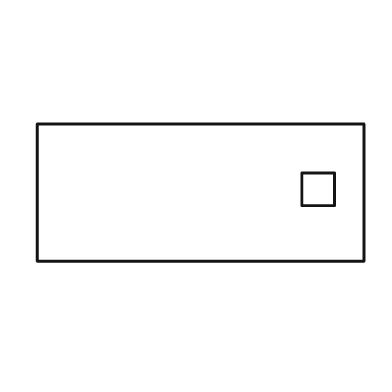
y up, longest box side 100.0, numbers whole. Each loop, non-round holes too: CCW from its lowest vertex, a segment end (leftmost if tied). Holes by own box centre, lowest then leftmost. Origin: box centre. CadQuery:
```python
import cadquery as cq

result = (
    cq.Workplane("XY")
    .moveTo(-50.0, -21.0)
    .lineTo(50.0, -21.0)
    .lineTo(50.0, 21.0)
    .lineTo(-50.0, 21.0)
    .close()
    .moveTo(31.0, -4.0)
    .lineTo(41.0, -4.0)
    .lineTo(41.0, 6.0)
    .lineTo(31.0, 6.0)
    .close()
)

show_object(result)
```